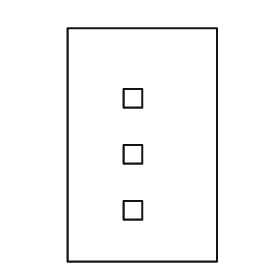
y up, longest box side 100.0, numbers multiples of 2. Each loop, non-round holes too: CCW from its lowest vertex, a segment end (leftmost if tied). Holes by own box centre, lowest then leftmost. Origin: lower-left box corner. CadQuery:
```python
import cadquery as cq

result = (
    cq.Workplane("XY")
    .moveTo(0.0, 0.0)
    .lineTo(64.0, 0.0)
    .lineTo(64.0, 100.0)
    .lineTo(0.0, 100.0)
    .close()
    .moveTo(24.0, 18.0)
    .lineTo(32.0, 18.0)
    .lineTo(32.0, 26.0)
    .lineTo(24.0, 26.0)
    .close()
    .moveTo(24.0, 42.0)
    .lineTo(32.0, 42.0)
    .lineTo(32.0, 50.0)
    .lineTo(24.0, 50.0)
    .close()
    .moveTo(24.0, 66.0)
    .lineTo(32.0, 66.0)
    .lineTo(32.0, 74.0)
    .lineTo(24.0, 74.0)
    .close()
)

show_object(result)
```